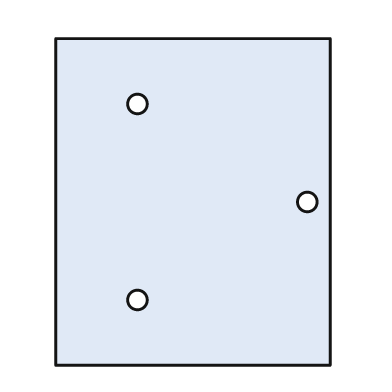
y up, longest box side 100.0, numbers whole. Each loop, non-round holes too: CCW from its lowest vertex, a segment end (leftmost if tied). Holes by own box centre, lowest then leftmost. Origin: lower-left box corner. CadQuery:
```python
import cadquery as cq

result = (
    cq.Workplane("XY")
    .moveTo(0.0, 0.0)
    .lineTo(84.0, 0.0)
    .lineTo(84.0, 100.0)
    .lineTo(0.0, 100.0)
    .close()
    .moveTo(25.0, 20.0)
    .circle(3.0)
    .moveTo(77.0, 50.0)
    .circle(3.0)
    .moveTo(25.0, 80.0)
    .circle(3.0)
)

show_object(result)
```